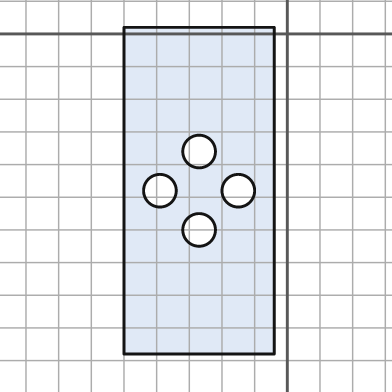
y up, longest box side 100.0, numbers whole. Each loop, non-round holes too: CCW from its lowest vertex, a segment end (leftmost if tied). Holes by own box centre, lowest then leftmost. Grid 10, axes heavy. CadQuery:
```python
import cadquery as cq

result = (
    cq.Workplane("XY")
    .moveTo(-50.0, -98.0)
    .lineTo(-4.0, -98.0)
    .lineTo(-4.0, 2.0)
    .lineTo(-50.0, 2.0)
    .close()
    .moveTo(-27.0, -60.0)
    .circle(5.0)
    .moveTo(-39.0, -48.0)
    .circle(5.0)
    .moveTo(-15.0, -48.0)
    .circle(5.0)
    .moveTo(-27.0, -36.0)
    .circle(5.0)
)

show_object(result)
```